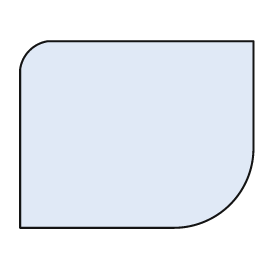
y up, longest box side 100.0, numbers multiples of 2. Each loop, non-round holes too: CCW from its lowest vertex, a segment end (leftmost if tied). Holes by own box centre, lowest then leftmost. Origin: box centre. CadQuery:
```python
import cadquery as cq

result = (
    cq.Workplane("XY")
    .moveTo(-50.0, -40.0)
    .lineTo(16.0, -40.0)
    .threePointArc((40.0, -30.0), (50.0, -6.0))
    .lineTo(50.0, 40.0)
    .lineTo(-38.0, 40.0)
    .threePointArc((-46.0, 36.0), (-50.0, 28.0))
    .close()
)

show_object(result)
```